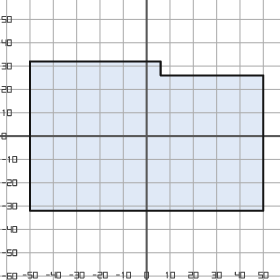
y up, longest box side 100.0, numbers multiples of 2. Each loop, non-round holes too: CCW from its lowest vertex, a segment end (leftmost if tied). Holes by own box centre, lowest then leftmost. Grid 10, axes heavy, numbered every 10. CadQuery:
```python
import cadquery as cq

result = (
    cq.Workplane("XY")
    .moveTo(-50.0, -32.0)
    .lineTo(50.0, -32.0)
    .lineTo(50.0, 26.0)
    .lineTo(6.0, 26.0)
    .lineTo(6.0, 32.0)
    .lineTo(-50.0, 32.0)
    .close()
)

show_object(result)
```